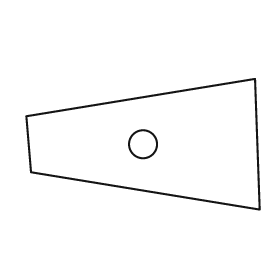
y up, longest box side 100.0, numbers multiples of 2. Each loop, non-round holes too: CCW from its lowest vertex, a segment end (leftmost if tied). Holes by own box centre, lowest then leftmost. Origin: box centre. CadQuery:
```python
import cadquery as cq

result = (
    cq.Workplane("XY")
    .moveTo(50.0, -28.0)
    .lineTo(48.0, 28.0)
    .lineTo(-50.0, 12.0)
    .lineTo(-48.0, -12.0)
    .close()
    .moveTo(0.0, 0.0)
    .circle(6.0)
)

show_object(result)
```